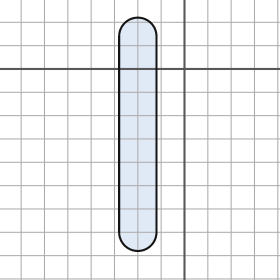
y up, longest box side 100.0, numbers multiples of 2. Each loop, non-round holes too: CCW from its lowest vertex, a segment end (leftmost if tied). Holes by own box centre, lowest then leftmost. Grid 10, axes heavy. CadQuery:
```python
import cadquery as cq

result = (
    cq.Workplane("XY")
    .moveTo(-28.0, -70.0)
    .threePointArc((-20.0, -78.0), (-12.0, -70.0))
    .lineTo(-12.0, 14.0)
    .threePointArc((-20.0, 22.0), (-28.0, 14.0))
    .close()
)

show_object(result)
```